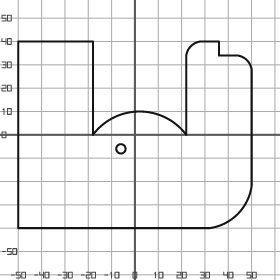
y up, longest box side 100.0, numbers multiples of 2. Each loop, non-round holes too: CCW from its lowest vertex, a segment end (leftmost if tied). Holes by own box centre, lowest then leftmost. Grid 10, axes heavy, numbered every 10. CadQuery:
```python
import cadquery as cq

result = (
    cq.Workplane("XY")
    .moveTo(-50.0, -40.0)
    .lineTo(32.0, -40.0)
    .threePointArc((44.0, -34.0), (50.0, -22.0))
    .lineTo(50.0, 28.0)
    .threePointArc((48.0, 32.0), (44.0, 34.0))
    .lineTo(36.0, 34.0)
    .lineTo(36.0, 40.0)
    .lineTo(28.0, 40.0)
    .threePointArc((24.0, 38.0), (22.0, 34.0))
    .lineTo(22.0, 0.0)
    .threePointArc((2.0, 10.0), (-18.0, 0.0))
    .lineTo(-18.0, 40.0)
    .lineTo(-50.0, 40.0)
    .close()
    .moveTo(-6.0, -6.0)
    .circle(2.0)
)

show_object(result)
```